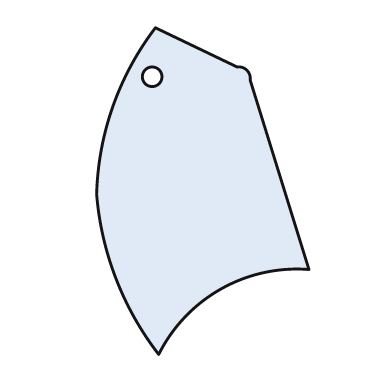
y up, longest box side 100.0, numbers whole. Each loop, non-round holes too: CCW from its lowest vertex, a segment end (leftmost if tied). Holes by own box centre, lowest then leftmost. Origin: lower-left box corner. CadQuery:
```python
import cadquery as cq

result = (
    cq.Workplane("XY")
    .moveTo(19.0, 0.0)
    .threePointArc((38.0, 20.0), (65.0, 26.0))
    .lineTo(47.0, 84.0)
    .threePointArc((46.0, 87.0), (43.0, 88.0))
    .lineTo(18.0, 100.0)
    .threePointArc((5.0, 76.0), (0.0, 49.0))
    .threePointArc((6.0, 23.0), (19.0, 0.0))
    .close()
    .moveTo(17.0, 85.0)
    .circle(3.0)
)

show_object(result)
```